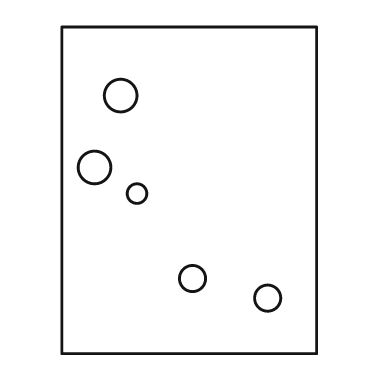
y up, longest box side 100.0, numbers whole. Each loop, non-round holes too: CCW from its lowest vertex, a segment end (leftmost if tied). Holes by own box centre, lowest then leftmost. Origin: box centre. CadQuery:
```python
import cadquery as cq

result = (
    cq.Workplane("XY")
    .moveTo(-39.0, -50.0)
    .lineTo(39.0, -50.0)
    .lineTo(39.0, 50.0)
    .lineTo(-39.0, 50.0)
    .close()
    .moveTo(24.0, -33.0)
    .circle(4.0)
    .moveTo(1.0, -27.0)
    .circle(4.0)
    .moveTo(-16.0, -1.0)
    .circle(3.0)
    .moveTo(-29.0, 7.0)
    .circle(5.0)
    .moveTo(-21.0, 29.0)
    .circle(5.0)
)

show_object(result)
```